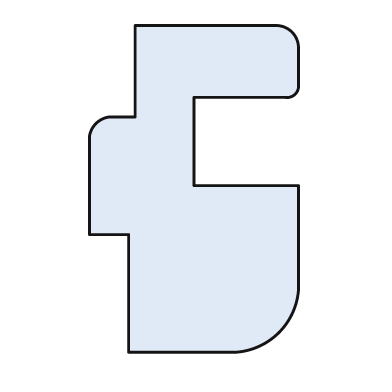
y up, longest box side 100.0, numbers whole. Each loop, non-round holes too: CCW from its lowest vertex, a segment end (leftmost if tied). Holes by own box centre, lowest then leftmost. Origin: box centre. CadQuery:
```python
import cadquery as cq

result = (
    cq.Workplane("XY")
    .moveTo(-20.0, -50.0)
    .lineTo(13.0, -50.0)
    .threePointArc((26.0, -44.0), (32.0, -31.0))
    .lineTo(32.0, 1.0)
    .lineTo(0.0, 1.0)
    .lineTo(0.0, 28.0)
    .lineTo(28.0, 28.0)
    .threePointArc((31.0, 29.0), (32.0, 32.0))
    .lineTo(32.0, 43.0)
    .threePointArc((30.0, 48.0), (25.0, 50.0))
    .lineTo(-18.0, 50.0)
    .lineTo(-18.0, 22.0)
    .lineTo(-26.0, 22.0)
    .threePointArc((-30.0, 20.0), (-32.0, 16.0))
    .lineTo(-32.0, -14.0)
    .lineTo(-20.0, -14.0)
    .close()
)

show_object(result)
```